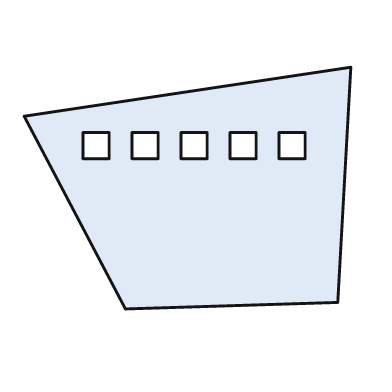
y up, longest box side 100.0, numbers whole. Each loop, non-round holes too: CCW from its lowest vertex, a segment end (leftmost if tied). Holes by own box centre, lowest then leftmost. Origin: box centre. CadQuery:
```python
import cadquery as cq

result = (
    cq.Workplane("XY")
    .moveTo(-19.0, -37.0)
    .lineTo(46.0, -35.0)
    .lineTo(50.0, 37.0)
    .lineTo(-50.0, 22.0)
    .close()
    .moveTo(-32.0, 9.0)
    .lineTo(-24.0, 9.0)
    .lineTo(-24.0, 17.0)
    .lineTo(-32.0, 17.0)
    .close()
    .moveTo(-17.0, 9.0)
    .lineTo(-9.0, 9.0)
    .lineTo(-9.0, 17.0)
    .lineTo(-17.0, 17.0)
    .close()
    .moveTo(-2.0, 9.0)
    .lineTo(6.0, 9.0)
    .lineTo(6.0, 17.0)
    .lineTo(-2.0, 17.0)
    .close()
    .moveTo(13.0, 9.0)
    .lineTo(21.0, 9.0)
    .lineTo(21.0, 17.0)
    .lineTo(13.0, 17.0)
    .close()
    .moveTo(28.0, 9.0)
    .lineTo(36.0, 9.0)
    .lineTo(36.0, 17.0)
    .lineTo(28.0, 17.0)
    .close()
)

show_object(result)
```